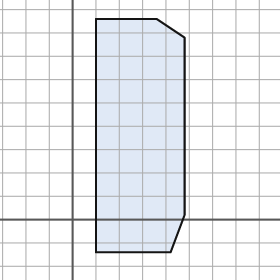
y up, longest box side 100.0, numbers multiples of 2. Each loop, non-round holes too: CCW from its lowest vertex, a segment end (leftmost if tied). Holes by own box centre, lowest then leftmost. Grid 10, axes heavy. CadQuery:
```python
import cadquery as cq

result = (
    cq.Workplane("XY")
    .moveTo(10.0, -14.0)
    .lineTo(42.0, -14.0)
    .lineTo(48.0, 2.0)
    .lineTo(48.0, 78.0)
    .lineTo(36.0, 86.0)
    .lineTo(10.0, 86.0)
    .close()
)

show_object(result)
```